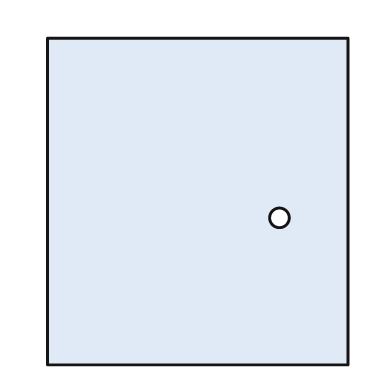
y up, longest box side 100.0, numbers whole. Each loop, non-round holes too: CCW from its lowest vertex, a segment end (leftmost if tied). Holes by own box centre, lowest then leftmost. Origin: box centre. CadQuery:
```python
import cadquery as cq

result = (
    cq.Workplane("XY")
    .moveTo(-46.0, -50.0)
    .lineTo(46.0, -50.0)
    .lineTo(46.0, 50.0)
    .lineTo(-46.0, 50.0)
    .close()
    .moveTo(25.0, -5.0)
    .circle(3.0)
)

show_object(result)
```